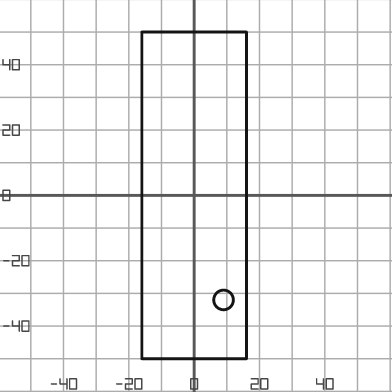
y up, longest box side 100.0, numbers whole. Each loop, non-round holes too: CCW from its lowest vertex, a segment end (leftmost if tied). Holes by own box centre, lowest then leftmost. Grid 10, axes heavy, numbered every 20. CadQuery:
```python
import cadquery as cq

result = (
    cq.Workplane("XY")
    .moveTo(-16.0, -50.0)
    .lineTo(16.0, -50.0)
    .lineTo(16.0, 50.0)
    .lineTo(-16.0, 50.0)
    .close()
    .moveTo(9.0, -32.0)
    .circle(3.0)
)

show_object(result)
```